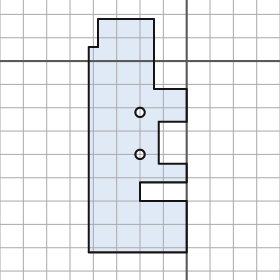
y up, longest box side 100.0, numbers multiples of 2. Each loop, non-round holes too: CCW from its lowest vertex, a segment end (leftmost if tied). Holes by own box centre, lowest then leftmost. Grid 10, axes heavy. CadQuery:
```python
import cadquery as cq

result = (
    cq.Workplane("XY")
    .moveTo(-42.0, -82.0)
    .lineTo(0.0, -82.0)
    .lineTo(0.0, -60.0)
    .lineTo(-20.0, -60.0)
    .lineTo(-20.0, -52.0)
    .lineTo(0.0, -52.0)
    .lineTo(0.0, -44.0)
    .lineTo(-12.0, -44.0)
    .lineTo(-12.0, -26.0)
    .lineTo(0.0, -26.0)
    .lineTo(0.0, -12.0)
    .lineTo(-14.0, -12.0)
    .lineTo(-14.0, 18.0)
    .lineTo(-38.0, 18.0)
    .lineTo(-38.0, 6.0)
    .lineTo(-42.0, 6.0)
    .close()
    .moveTo(-20.0, -40.0)
    .circle(2.0)
    .moveTo(-20.0, -22.0)
    .circle(2.0)
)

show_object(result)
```